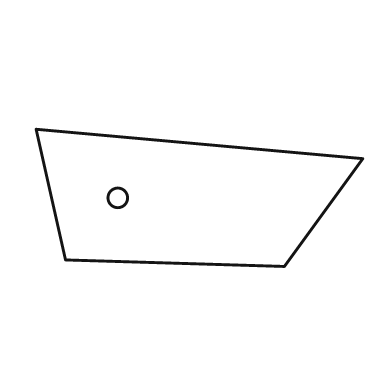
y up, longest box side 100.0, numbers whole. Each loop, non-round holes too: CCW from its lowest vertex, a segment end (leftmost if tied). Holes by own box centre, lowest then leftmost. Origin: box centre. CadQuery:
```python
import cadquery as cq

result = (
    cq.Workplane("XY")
    .moveTo(26.0, -21.0)
    .lineTo(50.0, 12.0)
    .lineTo(-50.0, 21.0)
    .lineTo(-41.0, -19.0)
    .close()
    .moveTo(-25.0, 0.0)
    .circle(3.0)
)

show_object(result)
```